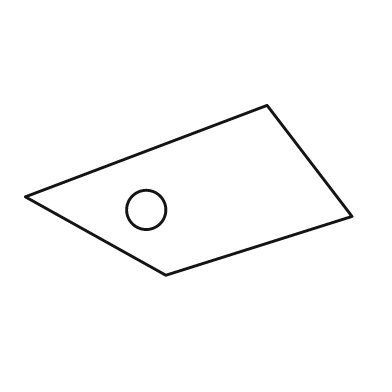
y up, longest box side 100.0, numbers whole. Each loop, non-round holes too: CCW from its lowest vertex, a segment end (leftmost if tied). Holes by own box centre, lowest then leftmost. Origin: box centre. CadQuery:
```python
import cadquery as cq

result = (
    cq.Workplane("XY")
    .moveTo(-7.0, -26.0)
    .lineTo(50.0, -8.0)
    .lineTo(24.0, 26.0)
    .lineTo(-50.0, -2.0)
    .close()
    .moveTo(-13.0, -6.0)
    .circle(6.0)
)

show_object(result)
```